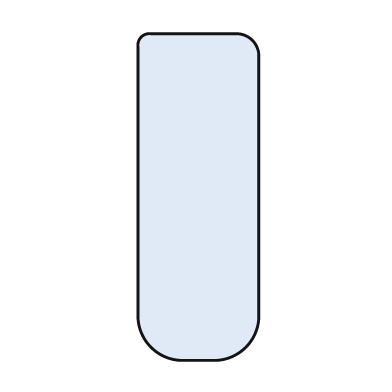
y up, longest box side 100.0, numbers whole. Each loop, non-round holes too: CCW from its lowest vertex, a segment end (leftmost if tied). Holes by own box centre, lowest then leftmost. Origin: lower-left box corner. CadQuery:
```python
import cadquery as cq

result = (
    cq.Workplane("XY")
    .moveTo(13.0, 0.0)
    .lineTo(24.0, 0.0)
    .threePointArc((33.0, 4.0), (37.0, 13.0))
    .lineTo(37.0, 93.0)
    .threePointArc((35.0, 98.0), (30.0, 100.0))
    .lineTo(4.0, 100.0)
    .threePointArc((1.0, 99.0), (0.0, 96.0))
    .lineTo(0.0, 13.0)
    .threePointArc((4.0, 4.0), (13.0, 0.0))
    .close()
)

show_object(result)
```